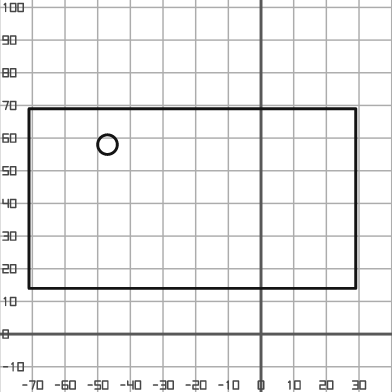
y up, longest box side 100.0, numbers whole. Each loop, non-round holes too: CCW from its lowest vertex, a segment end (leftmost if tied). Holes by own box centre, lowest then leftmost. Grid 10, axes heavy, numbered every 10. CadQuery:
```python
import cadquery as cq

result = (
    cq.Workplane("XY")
    .moveTo(-71.0, 14.0)
    .lineTo(29.0, 14.0)
    .lineTo(29.0, 69.0)
    .lineTo(-71.0, 69.0)
    .close()
    .moveTo(-47.0, 58.0)
    .circle(3.0)
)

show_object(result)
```